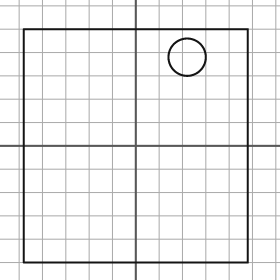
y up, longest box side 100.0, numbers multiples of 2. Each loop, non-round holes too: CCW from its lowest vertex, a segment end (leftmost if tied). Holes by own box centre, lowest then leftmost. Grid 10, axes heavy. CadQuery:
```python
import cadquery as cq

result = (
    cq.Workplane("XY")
    .moveTo(-48.0, -50.0)
    .lineTo(48.0, -50.0)
    .lineTo(48.0, 50.0)
    .lineTo(-48.0, 50.0)
    .close()
    .moveTo(22.0, 38.0)
    .circle(8.0)
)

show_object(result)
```